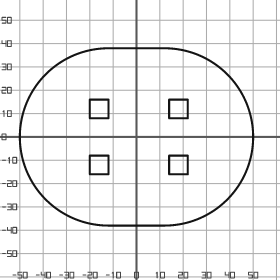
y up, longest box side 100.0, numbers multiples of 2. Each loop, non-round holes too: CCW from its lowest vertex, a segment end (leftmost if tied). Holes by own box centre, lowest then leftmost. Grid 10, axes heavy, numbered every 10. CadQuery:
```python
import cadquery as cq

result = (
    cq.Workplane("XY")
    .moveTo(-12.0, -38.0)
    .lineTo(12.0, -38.0)
    .threePointArc((50.0, 0.0), (12.0, 38.0))
    .lineTo(-12.0, 38.0)
    .threePointArc((-50.0, 0.0), (-12.0, -38.0))
    .close()
    .moveTo(-20.0, -16.0)
    .lineTo(-12.0, -16.0)
    .lineTo(-12.0, -8.0)
    .lineTo(-20.0, -8.0)
    .close()
    .moveTo(14.0, -16.0)
    .lineTo(22.0, -16.0)
    .lineTo(22.0, -8.0)
    .lineTo(14.0, -8.0)
    .close()
    .moveTo(-20.0, 8.0)
    .lineTo(-12.0, 8.0)
    .lineTo(-12.0, 16.0)
    .lineTo(-20.0, 16.0)
    .close()
    .moveTo(14.0, 8.0)
    .lineTo(22.0, 8.0)
    .lineTo(22.0, 16.0)
    .lineTo(14.0, 16.0)
    .close()
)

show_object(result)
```